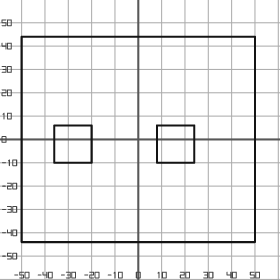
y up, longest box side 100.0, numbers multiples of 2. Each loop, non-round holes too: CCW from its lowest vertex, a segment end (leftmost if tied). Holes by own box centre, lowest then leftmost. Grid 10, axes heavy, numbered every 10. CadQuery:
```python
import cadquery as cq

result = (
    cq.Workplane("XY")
    .moveTo(-50.0, -44.0)
    .lineTo(50.0, -44.0)
    .lineTo(50.0, 44.0)
    .lineTo(-50.0, 44.0)
    .close()
    .moveTo(-36.0, -10.0)
    .lineTo(-20.0, -10.0)
    .lineTo(-20.0, 6.0)
    .lineTo(-36.0, 6.0)
    .close()
    .moveTo(8.0, -10.0)
    .lineTo(24.0, -10.0)
    .lineTo(24.0, 6.0)
    .lineTo(8.0, 6.0)
    .close()
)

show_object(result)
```